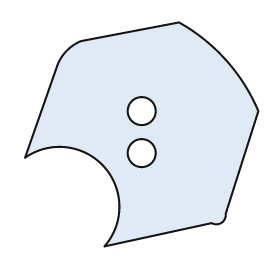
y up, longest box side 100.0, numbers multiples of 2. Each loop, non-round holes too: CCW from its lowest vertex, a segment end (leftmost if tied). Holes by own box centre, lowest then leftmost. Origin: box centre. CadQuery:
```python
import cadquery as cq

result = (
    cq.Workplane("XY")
    .moveTo(-16.0, -48.0)
    .lineTo(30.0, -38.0)
    .threePointArc((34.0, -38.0), (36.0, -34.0))
    .lineTo(50.0, 10.0)
    .threePointArc((36.0, 32.0), (16.0, 48.0))
    .lineTo(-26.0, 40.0)
    .threePointArc((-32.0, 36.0), (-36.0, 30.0))
    .lineTo(-50.0, -10.0)
    .threePointArc((-16.0, -14.0), (-16.0, -48.0))
    .close()
    .moveTo(0.0, -8.0)
    .circle(6.0)
    .moveTo(0.0, 10.0)
    .circle(6.0)
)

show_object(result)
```